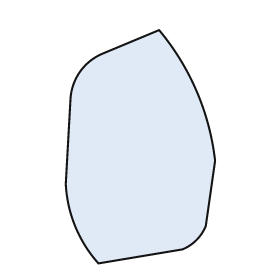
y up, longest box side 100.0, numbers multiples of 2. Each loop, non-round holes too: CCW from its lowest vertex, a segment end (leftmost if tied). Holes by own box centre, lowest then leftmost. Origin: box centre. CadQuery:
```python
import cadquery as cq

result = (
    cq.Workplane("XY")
    .moveTo(-18.0, -50.0)
    .lineTo(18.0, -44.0)
    .threePointArc((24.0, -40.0), (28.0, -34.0))
    .lineTo(32.0, -6.0)
    .threePointArc((24.0, 24.0), (8.0, 50.0))
    .lineTo(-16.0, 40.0)
    .threePointArc((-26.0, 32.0), (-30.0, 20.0))
    .lineTo(-32.0, -16.0)
    .threePointArc((-28.0, -34.0), (-18.0, -50.0))
    .close()
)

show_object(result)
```